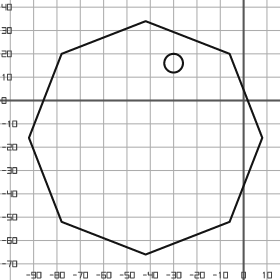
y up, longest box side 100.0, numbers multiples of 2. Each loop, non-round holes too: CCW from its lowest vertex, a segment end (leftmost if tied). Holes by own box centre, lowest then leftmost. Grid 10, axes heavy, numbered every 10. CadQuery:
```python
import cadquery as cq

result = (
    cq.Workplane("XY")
    .moveTo(-42.0, -66.0)
    .lineTo(-6.0, -52.0)
    .lineTo(8.0, -16.0)
    .lineTo(-6.0, 20.0)
    .lineTo(-42.0, 34.0)
    .lineTo(-78.0, 20.0)
    .lineTo(-92.0, -16.0)
    .lineTo(-78.0, -52.0)
    .close()
    .moveTo(-30.0, 16.0)
    .circle(4.0)
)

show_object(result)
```